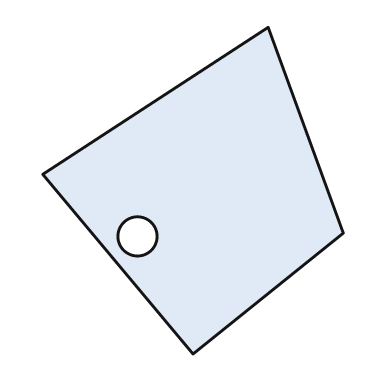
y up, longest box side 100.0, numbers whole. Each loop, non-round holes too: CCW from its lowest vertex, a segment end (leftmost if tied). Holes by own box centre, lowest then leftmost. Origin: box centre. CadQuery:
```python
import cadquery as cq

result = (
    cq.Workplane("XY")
    .moveTo(0.0, -50.0)
    .lineTo(46.0, -13.0)
    .lineTo(23.0, 50.0)
    .lineTo(-46.0, 5.0)
    .close()
    .moveTo(-17.0, -14.0)
    .circle(6.0)
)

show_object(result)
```